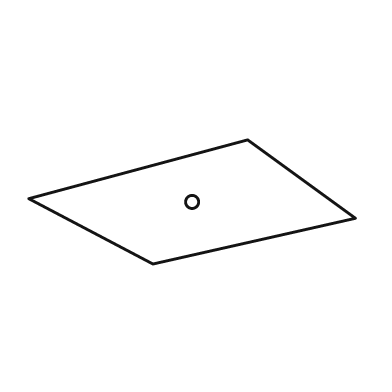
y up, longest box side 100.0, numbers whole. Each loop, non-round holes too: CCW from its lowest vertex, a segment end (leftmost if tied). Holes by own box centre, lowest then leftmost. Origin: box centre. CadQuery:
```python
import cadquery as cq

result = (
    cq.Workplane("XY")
    .moveTo(-12.0, -19.0)
    .lineTo(50.0, -5.0)
    .lineTo(17.0, 19.0)
    .lineTo(-50.0, 1.0)
    .close()
    .moveTo(0.0, 0.0)
    .circle(2.0)
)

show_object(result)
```